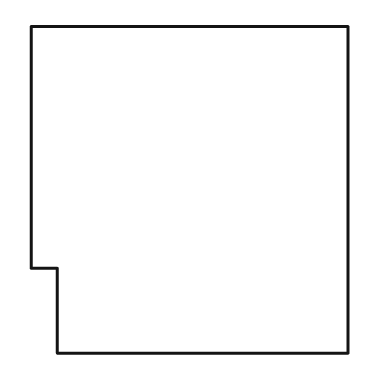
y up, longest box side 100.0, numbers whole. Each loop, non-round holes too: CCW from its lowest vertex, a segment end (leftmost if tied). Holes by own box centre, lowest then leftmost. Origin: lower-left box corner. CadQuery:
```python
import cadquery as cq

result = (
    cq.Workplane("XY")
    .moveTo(8.0, 0.0)
    .lineTo(97.0, 0.0)
    .lineTo(97.0, 100.0)
    .lineTo(0.0, 100.0)
    .lineTo(0.0, 26.0)
    .lineTo(8.0, 26.0)
    .close()
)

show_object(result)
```